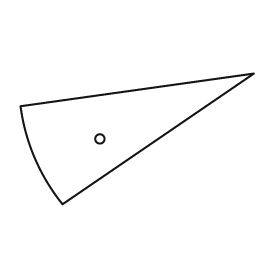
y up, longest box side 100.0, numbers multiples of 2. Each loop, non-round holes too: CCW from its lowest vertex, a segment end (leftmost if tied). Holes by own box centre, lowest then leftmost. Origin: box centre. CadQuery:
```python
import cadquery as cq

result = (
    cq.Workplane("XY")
    .moveTo(-32.0, -28.0)
    .lineTo(50.0, 28.0)
    .lineTo(-50.0, 14.0)
    .threePointArc((-44.0, -8.0), (-32.0, -28.0))
    .close()
    .moveTo(-16.0, 0.0)
    .circle(2.0)
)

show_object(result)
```